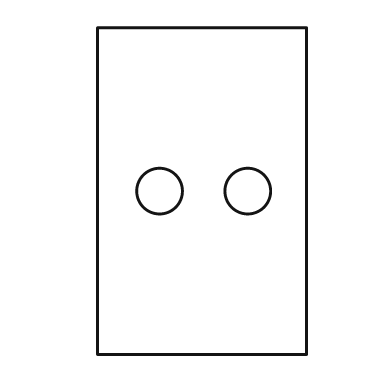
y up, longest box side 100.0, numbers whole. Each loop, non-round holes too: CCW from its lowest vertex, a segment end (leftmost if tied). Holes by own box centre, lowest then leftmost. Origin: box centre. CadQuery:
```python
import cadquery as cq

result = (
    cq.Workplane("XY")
    .moveTo(-32.0, -50.0)
    .lineTo(32.0, -50.0)
    .lineTo(32.0, 50.0)
    .lineTo(-32.0, 50.0)
    .close()
    .moveTo(-13.0, 0.0)
    .circle(7.0)
    .moveTo(14.0, 0.0)
    .circle(7.0)
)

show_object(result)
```